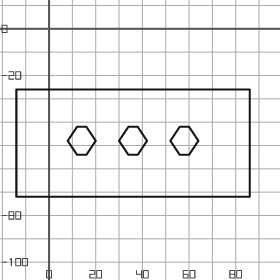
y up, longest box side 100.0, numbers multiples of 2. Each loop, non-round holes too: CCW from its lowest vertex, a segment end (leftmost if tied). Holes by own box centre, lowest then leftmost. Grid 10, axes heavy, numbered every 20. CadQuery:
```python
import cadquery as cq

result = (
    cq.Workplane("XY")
    .moveTo(-14.0, -72.0)
    .lineTo(86.0, -72.0)
    .lineTo(86.0, -26.0)
    .lineTo(-14.0, -26.0)
    .close()
    .moveTo(12.0, -54.0)
    .lineTo(16.0, -54.0)
    .lineTo(20.0, -48.0)
    .lineTo(16.0, -42.0)
    .lineTo(12.0, -42.0)
    .lineTo(8.0, -48.0)
    .close()
    .moveTo(34.0, -54.0)
    .lineTo(38.0, -54.0)
    .lineTo(42.0, -48.0)
    .lineTo(38.0, -42.0)
    .lineTo(34.0, -42.0)
    .lineTo(30.0, -48.0)
    .close()
    .moveTo(56.0, -54.0)
    .lineTo(60.0, -54.0)
    .lineTo(64.0, -48.0)
    .lineTo(60.0, -42.0)
    .lineTo(56.0, -42.0)
    .lineTo(52.0, -48.0)
    .close()
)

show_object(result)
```